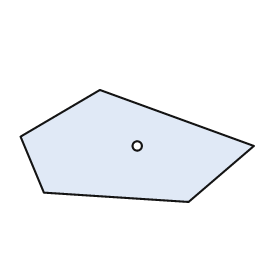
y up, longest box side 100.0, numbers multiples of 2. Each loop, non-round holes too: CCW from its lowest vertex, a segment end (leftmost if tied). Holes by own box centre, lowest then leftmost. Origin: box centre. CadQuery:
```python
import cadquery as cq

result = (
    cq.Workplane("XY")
    .moveTo(22.0, -24.0)
    .lineTo(50.0, 0.0)
    .lineTo(-16.0, 24.0)
    .lineTo(-50.0, 4.0)
    .lineTo(-40.0, -20.0)
    .close()
    .moveTo(0.0, 0.0)
    .circle(2.0)
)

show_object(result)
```